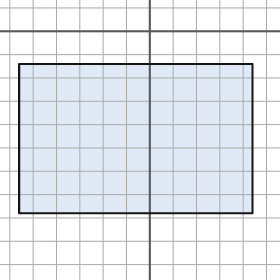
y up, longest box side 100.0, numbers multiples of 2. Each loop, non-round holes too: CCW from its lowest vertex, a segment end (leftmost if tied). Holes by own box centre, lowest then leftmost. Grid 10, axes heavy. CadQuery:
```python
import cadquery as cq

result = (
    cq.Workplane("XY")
    .moveTo(-56.0, -78.0)
    .lineTo(44.0, -78.0)
    .lineTo(44.0, -14.0)
    .lineTo(-56.0, -14.0)
    .close()
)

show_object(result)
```